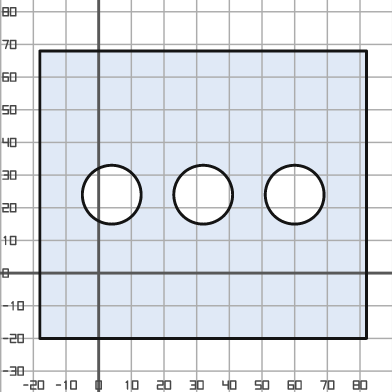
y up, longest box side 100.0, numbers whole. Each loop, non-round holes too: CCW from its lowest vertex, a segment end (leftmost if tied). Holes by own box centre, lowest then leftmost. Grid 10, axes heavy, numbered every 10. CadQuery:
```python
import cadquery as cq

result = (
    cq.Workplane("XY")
    .moveTo(-18.0, -20.0)
    .lineTo(82.0, -20.0)
    .lineTo(82.0, 68.0)
    .lineTo(-18.0, 68.0)
    .close()
    .moveTo(4.0, 24.0)
    .circle(9.0)
    .moveTo(32.0, 24.0)
    .circle(9.0)
    .moveTo(60.0, 24.0)
    .circle(9.0)
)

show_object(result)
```